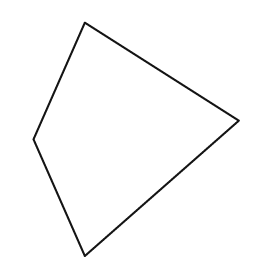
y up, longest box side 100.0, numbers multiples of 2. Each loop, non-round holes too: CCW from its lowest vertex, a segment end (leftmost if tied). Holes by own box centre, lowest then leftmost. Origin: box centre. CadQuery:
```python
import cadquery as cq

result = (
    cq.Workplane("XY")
    .moveTo(-22.0, -50.0)
    .lineTo(44.0, 8.0)
    .lineTo(-22.0, 50.0)
    .lineTo(-44.0, 0.0)
    .close()
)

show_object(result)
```